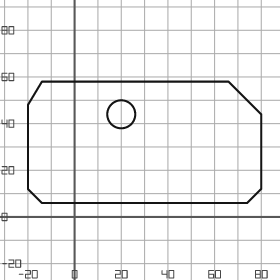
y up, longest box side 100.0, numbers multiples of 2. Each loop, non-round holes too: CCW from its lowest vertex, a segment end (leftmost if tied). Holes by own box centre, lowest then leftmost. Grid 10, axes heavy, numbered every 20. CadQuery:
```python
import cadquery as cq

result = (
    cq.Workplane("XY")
    .moveTo(-14.0, 6.0)
    .lineTo(74.0, 6.0)
    .lineTo(80.0, 12.0)
    .lineTo(80.0, 44.0)
    .lineTo(66.0, 58.0)
    .lineTo(-14.0, 58.0)
    .lineTo(-20.0, 48.0)
    .lineTo(-20.0, 12.0)
    .close()
    .moveTo(20.0, 44.0)
    .circle(6.0)
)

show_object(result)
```